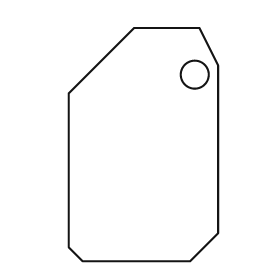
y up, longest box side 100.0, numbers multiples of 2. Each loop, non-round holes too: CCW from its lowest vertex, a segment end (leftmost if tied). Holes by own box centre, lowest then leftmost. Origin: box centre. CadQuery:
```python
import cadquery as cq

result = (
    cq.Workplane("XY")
    .moveTo(-26.0, -50.0)
    .lineTo(20.0, -50.0)
    .lineTo(32.0, -38.0)
    .lineTo(32.0, 34.0)
    .lineTo(24.0, 50.0)
    .lineTo(-4.0, 50.0)
    .lineTo(-32.0, 22.0)
    .lineTo(-32.0, -44.0)
    .close()
    .moveTo(22.0, 30.0)
    .circle(6.0)
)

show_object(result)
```